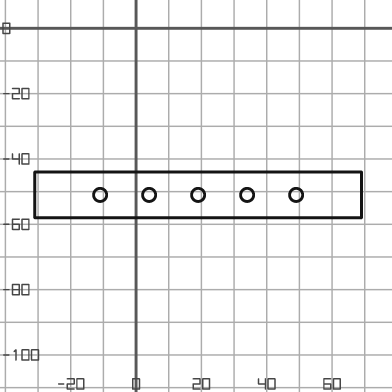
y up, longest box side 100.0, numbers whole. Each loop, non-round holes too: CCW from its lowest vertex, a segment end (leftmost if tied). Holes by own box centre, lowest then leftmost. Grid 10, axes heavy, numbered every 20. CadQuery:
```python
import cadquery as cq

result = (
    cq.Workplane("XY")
    .moveTo(-31.0, -58.0)
    .lineTo(69.0, -58.0)
    .lineTo(69.0, -44.0)
    .lineTo(-31.0, -44.0)
    .close()
    .moveTo(-11.0, -51.0)
    .circle(2.0)
    .moveTo(4.0, -51.0)
    .circle(2.0)
    .moveTo(19.0, -51.0)
    .circle(2.0)
    .moveTo(34.0, -51.0)
    .circle(2.0)
    .moveTo(49.0, -51.0)
    .circle(2.0)
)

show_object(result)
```